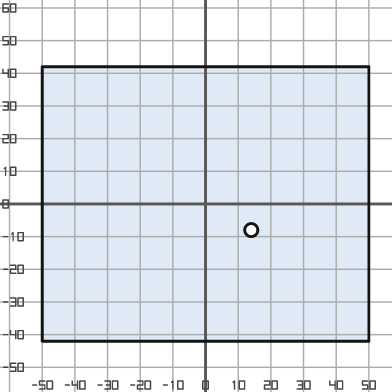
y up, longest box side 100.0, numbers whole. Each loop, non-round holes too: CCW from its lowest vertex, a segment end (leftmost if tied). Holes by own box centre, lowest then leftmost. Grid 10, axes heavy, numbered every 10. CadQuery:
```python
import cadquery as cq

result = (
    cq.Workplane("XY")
    .moveTo(-50.0, -42.0)
    .lineTo(50.0, -42.0)
    .lineTo(50.0, 42.0)
    .lineTo(-50.0, 42.0)
    .close()
    .moveTo(14.0, -8.0)
    .circle(2.0)
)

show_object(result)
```